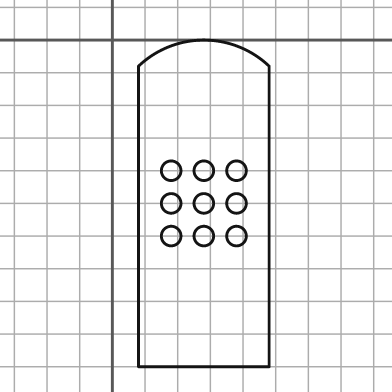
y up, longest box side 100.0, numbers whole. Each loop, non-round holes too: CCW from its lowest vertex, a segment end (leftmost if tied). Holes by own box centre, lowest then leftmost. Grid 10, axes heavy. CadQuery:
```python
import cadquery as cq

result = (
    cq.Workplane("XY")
    .moveTo(8.0, -100.0)
    .lineTo(48.0, -100.0)
    .lineTo(48.0, -8.0)
    .threePointArc((28.0, 0.0), (8.0, -8.0))
    .close()
    .moveTo(18.0, -60.0)
    .circle(3.0)
    .moveTo(28.0, -60.0)
    .circle(3.0)
    .moveTo(38.0, -60.0)
    .circle(3.0)
    .moveTo(18.0, -50.0)
    .circle(3.0)
    .moveTo(28.0, -50.0)
    .circle(3.0)
    .moveTo(38.0, -50.0)
    .circle(3.0)
    .moveTo(18.0, -40.0)
    .circle(3.0)
    .moveTo(28.0, -40.0)
    .circle(3.0)
    .moveTo(38.0, -40.0)
    .circle(3.0)
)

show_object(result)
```